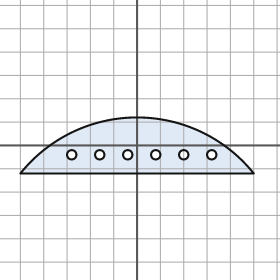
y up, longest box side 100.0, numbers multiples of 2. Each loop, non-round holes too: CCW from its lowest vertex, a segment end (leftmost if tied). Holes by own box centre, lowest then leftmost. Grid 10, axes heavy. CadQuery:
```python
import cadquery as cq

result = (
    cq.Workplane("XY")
    .moveTo(-50.0, -12.0)
    .lineTo(50.0, -12.0)
    .threePointArc((0.0, 12.0), (-50.0, -12.0))
    .close()
    .moveTo(-28.0, -4.0)
    .circle(2.0)
    .moveTo(-16.0, -4.0)
    .circle(2.0)
    .moveTo(-4.0, -4.0)
    .circle(2.0)
    .moveTo(8.0, -4.0)
    .circle(2.0)
    .moveTo(20.0, -4.0)
    .circle(2.0)
    .moveTo(32.0, -4.0)
    .circle(2.0)
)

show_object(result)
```